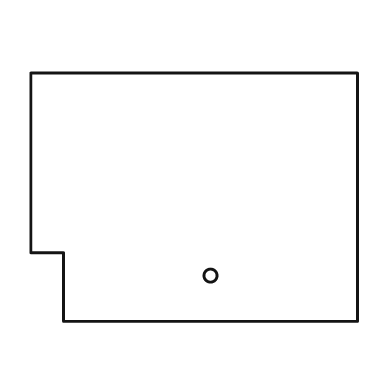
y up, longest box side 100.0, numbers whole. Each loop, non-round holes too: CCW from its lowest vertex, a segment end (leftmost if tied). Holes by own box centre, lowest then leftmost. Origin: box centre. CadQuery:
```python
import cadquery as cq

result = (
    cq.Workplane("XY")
    .moveTo(-40.0, -38.0)
    .lineTo(50.0, -38.0)
    .lineTo(50.0, 38.0)
    .lineTo(-50.0, 38.0)
    .lineTo(-50.0, -17.0)
    .lineTo(-40.0, -17.0)
    .close()
    .moveTo(5.0, -24.0)
    .circle(2.0)
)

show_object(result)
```